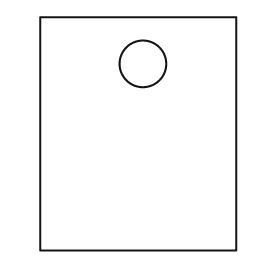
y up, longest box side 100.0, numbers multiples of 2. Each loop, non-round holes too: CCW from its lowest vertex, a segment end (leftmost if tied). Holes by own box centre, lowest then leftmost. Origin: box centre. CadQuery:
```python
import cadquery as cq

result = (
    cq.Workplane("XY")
    .moveTo(-42.0, -50.0)
    .lineTo(42.0, -50.0)
    .lineTo(42.0, 50.0)
    .lineTo(-42.0, 50.0)
    .close()
    .moveTo(2.0, 30.0)
    .circle(10.0)
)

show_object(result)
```